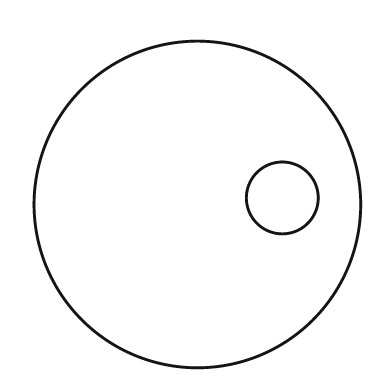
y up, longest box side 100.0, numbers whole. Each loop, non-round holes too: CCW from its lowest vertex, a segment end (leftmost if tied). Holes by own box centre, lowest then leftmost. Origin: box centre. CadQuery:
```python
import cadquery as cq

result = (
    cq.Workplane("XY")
    .moveTo(0.0, 0.0)
    .circle(50.0)
    .moveTo(26.0, 2.0)
    .circle(11.0)
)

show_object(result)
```